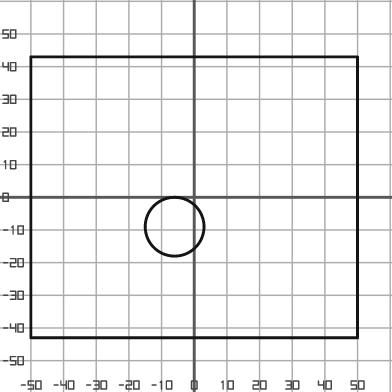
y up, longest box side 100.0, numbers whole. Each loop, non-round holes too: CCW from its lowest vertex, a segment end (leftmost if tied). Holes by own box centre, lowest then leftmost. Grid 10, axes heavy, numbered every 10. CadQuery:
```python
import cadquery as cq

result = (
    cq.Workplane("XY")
    .moveTo(-50.0, -43.0)
    .lineTo(50.0, -43.0)
    .lineTo(50.0, 43.0)
    .lineTo(-50.0, 43.0)
    .close()
    .moveTo(-6.0, -9.0)
    .circle(9.0)
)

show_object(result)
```